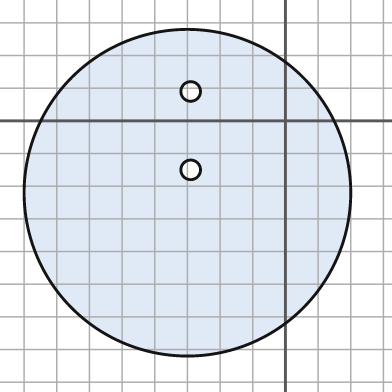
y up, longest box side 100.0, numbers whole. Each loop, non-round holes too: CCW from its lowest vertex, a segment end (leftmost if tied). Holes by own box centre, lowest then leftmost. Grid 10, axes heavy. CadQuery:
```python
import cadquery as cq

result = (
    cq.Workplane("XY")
    .moveTo(-30.0, -22.0)
    .circle(50.0)
    .moveTo(-29.0, -15.0)
    .circle(3.0)
    .moveTo(-29.0, 9.0)
    .circle(3.0)
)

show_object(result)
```